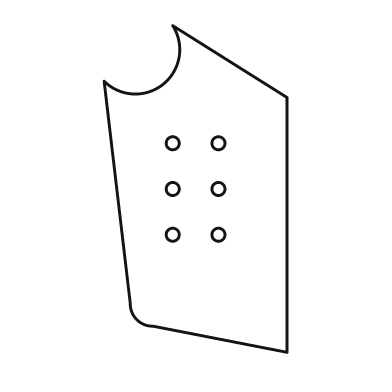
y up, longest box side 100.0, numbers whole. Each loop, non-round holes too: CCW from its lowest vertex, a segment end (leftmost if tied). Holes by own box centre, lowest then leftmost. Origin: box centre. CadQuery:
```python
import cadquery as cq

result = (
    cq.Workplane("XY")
    .moveTo(28.0, -50.0)
    .lineTo(28.0, 28.0)
    .lineTo(-7.0, 50.0)
    .threePointArc((-10.0, 32.0), (-28.0, 33.0))
    .lineTo(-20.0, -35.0)
    .threePointArc((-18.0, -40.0), (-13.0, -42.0))
    .close()
    .moveTo(-7.0, -14.0)
    .circle(2.0)
    .moveTo(7.0, -14.0)
    .circle(2.0)
    .moveTo(-7.0, 0.0)
    .circle(2.0)
    .moveTo(7.0, 0.0)
    .circle(2.0)
    .moveTo(-7.0, 14.0)
    .circle(2.0)
    .moveTo(7.0, 14.0)
    .circle(2.0)
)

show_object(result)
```